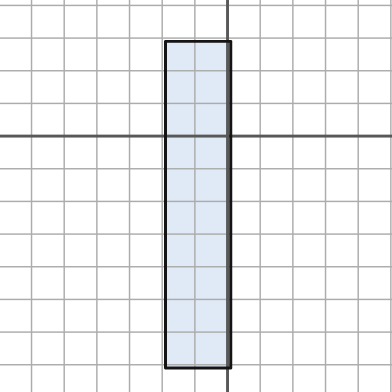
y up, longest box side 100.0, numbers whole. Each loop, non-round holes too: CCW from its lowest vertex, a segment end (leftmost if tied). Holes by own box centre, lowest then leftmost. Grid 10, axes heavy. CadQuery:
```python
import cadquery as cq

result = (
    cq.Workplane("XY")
    .moveTo(-19.0, -71.0)
    .lineTo(1.0, -71.0)
    .lineTo(1.0, 29.0)
    .lineTo(-19.0, 29.0)
    .close()
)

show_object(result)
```